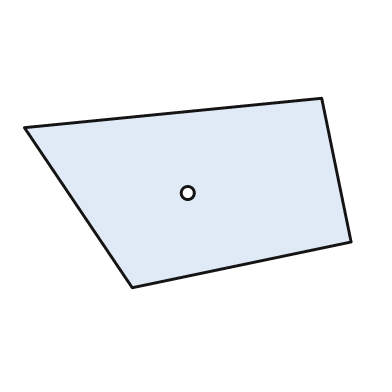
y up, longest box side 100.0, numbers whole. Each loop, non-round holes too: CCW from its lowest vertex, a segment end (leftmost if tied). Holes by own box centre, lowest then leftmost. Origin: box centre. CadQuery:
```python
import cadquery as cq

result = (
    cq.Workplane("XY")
    .moveTo(-17.0, -29.0)
    .lineTo(50.0, -15.0)
    .lineTo(41.0, 29.0)
    .lineTo(-50.0, 20.0)
    .close()
    .moveTo(0.0, 0.0)
    .circle(2.0)
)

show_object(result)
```